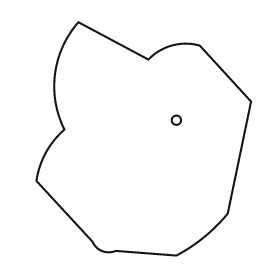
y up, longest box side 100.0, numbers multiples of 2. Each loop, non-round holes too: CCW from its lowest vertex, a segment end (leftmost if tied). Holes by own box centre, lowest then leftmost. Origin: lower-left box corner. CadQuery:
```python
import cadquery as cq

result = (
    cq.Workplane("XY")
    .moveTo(60.0, 0.0)
    .threePointArc((72.0, 8.0), (82.0, 18.0))
    .lineTo(92.0, 66.0)
    .lineTo(70.0, 90.0)
    .threePointArc((58.0, 90.0), (48.0, 84.0))
    .lineTo(18.0, 100.0)
    .threePointArc((8.0, 78.0), (12.0, 54.0))
    .threePointArc((4.0, 44.0), (0.0, 32.0))
    .lineTo(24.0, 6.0)
    .threePointArc((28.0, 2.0), (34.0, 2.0))
    .close()
    .moveTo(60.0, 58.0)
    .circle(2.0)
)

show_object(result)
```